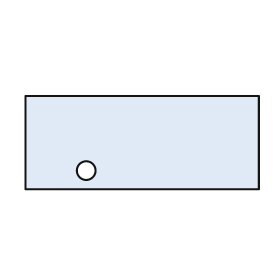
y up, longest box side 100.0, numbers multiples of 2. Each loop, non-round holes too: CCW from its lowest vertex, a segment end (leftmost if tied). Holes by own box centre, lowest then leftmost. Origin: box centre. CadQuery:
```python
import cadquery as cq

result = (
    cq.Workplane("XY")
    .moveTo(-50.0, -20.0)
    .lineTo(50.0, -20.0)
    .lineTo(50.0, 20.0)
    .lineTo(-50.0, 20.0)
    .close()
    .moveTo(-24.0, -12.0)
    .circle(4.0)
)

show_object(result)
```